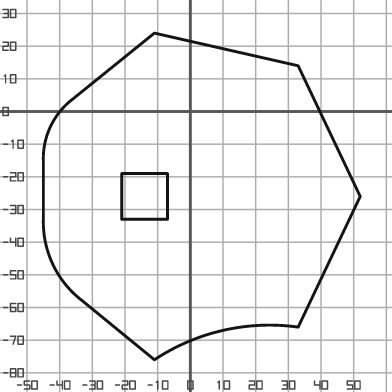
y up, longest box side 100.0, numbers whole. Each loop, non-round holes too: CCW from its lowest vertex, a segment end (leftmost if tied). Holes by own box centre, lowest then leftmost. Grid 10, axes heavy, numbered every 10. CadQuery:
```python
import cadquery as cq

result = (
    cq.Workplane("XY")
    .moveTo(-11.0, -76.0)
    .threePointArc((10.0, -67.0), (33.0, -66.0))
    .lineTo(52.0, -26.0)
    .lineTo(33.0, 14.0)
    .lineTo(-11.0, 24.0)
    .lineTo(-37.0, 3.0)
    .threePointArc((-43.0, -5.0), (-45.0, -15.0))
    .lineTo(-45.0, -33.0)
    .threePointArc((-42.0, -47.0), (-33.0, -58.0))
    .close()
    .moveTo(-21.0, -33.0)
    .lineTo(-7.0, -33.0)
    .lineTo(-7.0, -19.0)
    .lineTo(-21.0, -19.0)
    .close()
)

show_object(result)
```